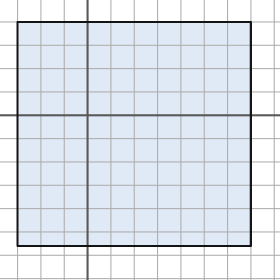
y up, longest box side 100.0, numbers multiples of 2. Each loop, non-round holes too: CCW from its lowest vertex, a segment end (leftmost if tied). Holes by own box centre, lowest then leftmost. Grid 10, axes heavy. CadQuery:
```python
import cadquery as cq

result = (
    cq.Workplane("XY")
    .moveTo(-30.0, -56.0)
    .lineTo(70.0, -56.0)
    .lineTo(70.0, 40.0)
    .lineTo(-30.0, 40.0)
    .close()
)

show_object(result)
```